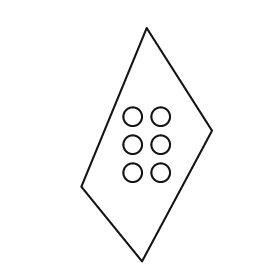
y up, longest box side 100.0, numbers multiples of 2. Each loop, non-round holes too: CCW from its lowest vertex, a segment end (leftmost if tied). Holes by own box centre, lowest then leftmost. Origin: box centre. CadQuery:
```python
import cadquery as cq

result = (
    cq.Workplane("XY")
    .moveTo(-2.0, -50.0)
    .lineTo(28.0, 6.0)
    .lineTo(0.0, 50.0)
    .lineTo(-28.0, -18.0)
    .close()
    .moveTo(-6.0, -12.0)
    .circle(4.0)
    .moveTo(6.0, -12.0)
    .circle(4.0)
    .moveTo(-6.0, 0.0)
    .circle(4.0)
    .moveTo(6.0, 0.0)
    .circle(4.0)
    .moveTo(-6.0, 12.0)
    .circle(4.0)
    .moveTo(6.0, 12.0)
    .circle(4.0)
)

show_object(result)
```